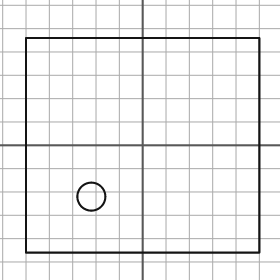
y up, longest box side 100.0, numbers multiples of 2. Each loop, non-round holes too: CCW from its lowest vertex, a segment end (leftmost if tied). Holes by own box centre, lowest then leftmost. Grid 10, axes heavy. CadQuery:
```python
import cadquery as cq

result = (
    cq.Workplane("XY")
    .moveTo(-50.0, -46.0)
    .lineTo(50.0, -46.0)
    .lineTo(50.0, 46.0)
    .lineTo(-50.0, 46.0)
    .close()
    .moveTo(-22.0, -22.0)
    .circle(6.0)
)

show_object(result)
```